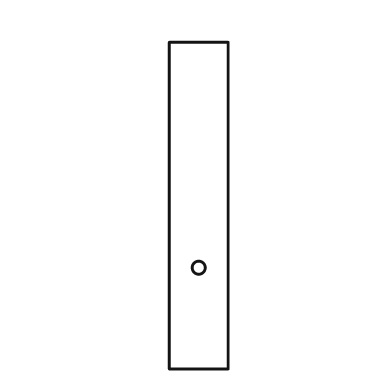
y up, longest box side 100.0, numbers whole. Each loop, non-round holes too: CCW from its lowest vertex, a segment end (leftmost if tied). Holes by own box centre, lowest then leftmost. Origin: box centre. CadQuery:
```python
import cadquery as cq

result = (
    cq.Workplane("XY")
    .moveTo(-9.0, -50.0)
    .lineTo(9.0, -50.0)
    .lineTo(9.0, 50.0)
    .lineTo(-9.0, 50.0)
    .close()
    .moveTo(0.0, -19.0)
    .circle(2.0)
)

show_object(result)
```